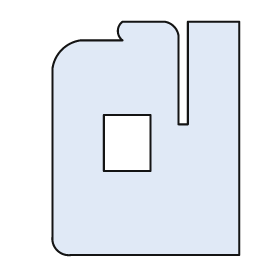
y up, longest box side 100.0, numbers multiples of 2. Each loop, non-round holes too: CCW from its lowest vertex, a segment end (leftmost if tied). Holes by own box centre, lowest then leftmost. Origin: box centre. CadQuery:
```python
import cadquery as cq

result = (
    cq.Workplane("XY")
    .moveTo(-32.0, -50.0)
    .lineTo(40.0, -50.0)
    .lineTo(40.0, 50.0)
    .lineTo(18.0, 50.0)
    .lineTo(18.0, 6.0)
    .lineTo(14.0, 6.0)
    .lineTo(14.0, 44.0)
    .threePointArc((12.0, 48.0), (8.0, 50.0))
    .lineTo(-10.0, 50.0)
    .threePointArc((-12.0, 46.0), (-10.0, 42.0))
    .lineTo(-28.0, 42.0)
    .threePointArc((-36.0, 38.0), (-40.0, 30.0))
    .lineTo(-40.0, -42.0)
    .threePointArc((-38.0, -48.0), (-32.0, -50.0))
    .close()
    .moveTo(-18.0, -14.0)
    .lineTo(2.0, -14.0)
    .lineTo(2.0, 10.0)
    .lineTo(-18.0, 10.0)
    .close()
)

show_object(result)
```